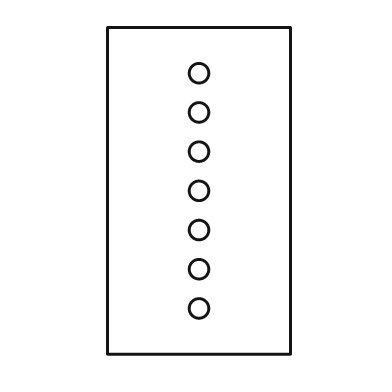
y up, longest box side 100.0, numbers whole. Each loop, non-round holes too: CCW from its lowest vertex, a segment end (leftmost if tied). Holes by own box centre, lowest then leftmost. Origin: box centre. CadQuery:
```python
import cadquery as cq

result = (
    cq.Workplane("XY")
    .moveTo(-28.0, -50.0)
    .lineTo(28.0, -50.0)
    .lineTo(28.0, 50.0)
    .lineTo(-28.0, 50.0)
    .close()
    .moveTo(0.0, -36.0)
    .circle(3.0)
    .moveTo(0.0, -24.0)
    .circle(3.0)
    .moveTo(0.0, -12.0)
    .circle(3.0)
    .moveTo(0.0, 0.0)
    .circle(3.0)
    .moveTo(0.0, 12.0)
    .circle(3.0)
    .moveTo(0.0, 24.0)
    .circle(3.0)
    .moveTo(0.0, 36.0)
    .circle(3.0)
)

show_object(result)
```